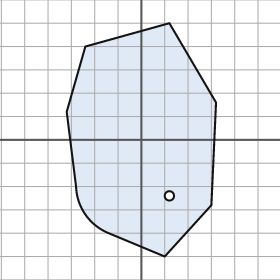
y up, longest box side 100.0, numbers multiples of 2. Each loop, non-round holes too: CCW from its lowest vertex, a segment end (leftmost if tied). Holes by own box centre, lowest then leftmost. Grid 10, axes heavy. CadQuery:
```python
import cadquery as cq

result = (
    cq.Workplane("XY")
    .moveTo(10.0, -50.0)
    .lineTo(30.0, -28.0)
    .lineTo(32.0, 16.0)
    .lineTo(12.0, 50.0)
    .lineTo(-24.0, 40.0)
    .lineTo(-32.0, 12.0)
    .lineTo(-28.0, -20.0)
    .threePointArc((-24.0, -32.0), (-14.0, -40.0))
    .close()
    .moveTo(12.0, -24.0)
    .circle(2.0)
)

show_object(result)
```